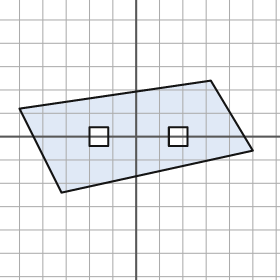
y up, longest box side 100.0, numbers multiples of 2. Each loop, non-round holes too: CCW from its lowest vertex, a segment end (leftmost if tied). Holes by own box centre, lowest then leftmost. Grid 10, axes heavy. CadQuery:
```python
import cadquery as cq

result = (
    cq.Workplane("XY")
    .moveTo(-32.0, -24.0)
    .lineTo(50.0, -6.0)
    .lineTo(32.0, 24.0)
    .lineTo(-50.0, 12.0)
    .close()
    .moveTo(-20.0, -4.0)
    .lineTo(-12.0, -4.0)
    .lineTo(-12.0, 4.0)
    .lineTo(-20.0, 4.0)
    .close()
    .moveTo(14.0, -4.0)
    .lineTo(22.0, -4.0)
    .lineTo(22.0, 4.0)
    .lineTo(14.0, 4.0)
    .close()
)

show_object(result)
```